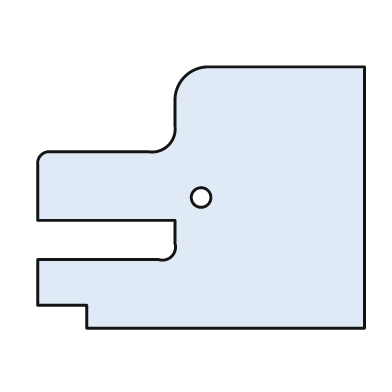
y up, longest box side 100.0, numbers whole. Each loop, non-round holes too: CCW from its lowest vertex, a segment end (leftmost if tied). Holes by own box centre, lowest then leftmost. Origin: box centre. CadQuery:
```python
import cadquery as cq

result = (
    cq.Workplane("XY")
    .moveTo(-35.0, -40.0)
    .lineTo(50.0, -40.0)
    .lineTo(50.0, 40.0)
    .lineTo(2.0, 40.0)
    .threePointArc((-5.0, 37.0), (-8.0, 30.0))
    .lineTo(-8.0, 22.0)
    .threePointArc((-10.0, 16.0), (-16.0, 14.0))
    .lineTo(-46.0, 14.0)
    .threePointArc((-49.0, 13.0), (-50.0, 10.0))
    .lineTo(-50.0, -7.0)
    .lineTo(-8.0, -7.0)
    .lineTo(-8.0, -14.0)
    .threePointArc((-9.0, -18.0), (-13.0, -19.0))
    .lineTo(-50.0, -19.0)
    .lineTo(-50.0, -33.0)
    .lineTo(-35.0, -33.0)
    .close()
    .moveTo(0.0, 0.0)
    .circle(3.0)
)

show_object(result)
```